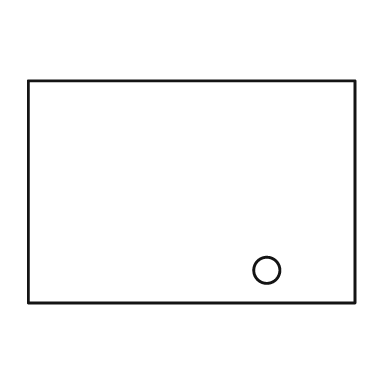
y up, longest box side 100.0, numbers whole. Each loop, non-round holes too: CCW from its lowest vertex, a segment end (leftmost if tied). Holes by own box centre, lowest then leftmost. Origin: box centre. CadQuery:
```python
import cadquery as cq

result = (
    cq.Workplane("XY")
    .moveTo(-50.0, -34.0)
    .lineTo(50.0, -34.0)
    .lineTo(50.0, 34.0)
    .lineTo(-50.0, 34.0)
    .close()
    .moveTo(23.0, -24.0)
    .circle(4.0)
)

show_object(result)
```